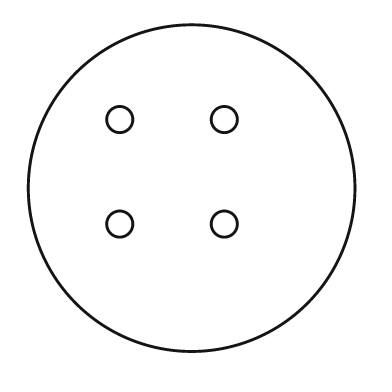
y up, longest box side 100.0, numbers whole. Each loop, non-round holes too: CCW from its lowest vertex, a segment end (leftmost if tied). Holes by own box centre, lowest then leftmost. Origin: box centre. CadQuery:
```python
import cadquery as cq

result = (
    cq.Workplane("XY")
    .moveTo(0.0, 0.0)
    .circle(50.0)
    .moveTo(-22.0, -11.0)
    .circle(4.0)
    .moveTo(10.0, -11.0)
    .circle(4.0)
    .moveTo(-22.0, 21.0)
    .circle(4.0)
    .moveTo(10.0, 21.0)
    .circle(4.0)
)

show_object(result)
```